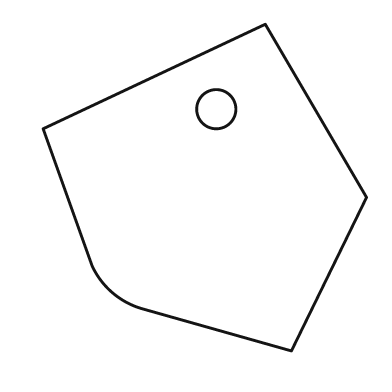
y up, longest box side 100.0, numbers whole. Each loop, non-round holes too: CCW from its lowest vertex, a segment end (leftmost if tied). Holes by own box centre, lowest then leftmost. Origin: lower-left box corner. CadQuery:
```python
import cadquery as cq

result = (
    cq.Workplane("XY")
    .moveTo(76.0, 0.0)
    .lineTo(99.0, 47.0)
    .lineTo(68.0, 100.0)
    .lineTo(0.0, 68.0)
    .lineTo(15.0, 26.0)
    .threePointArc((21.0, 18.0), (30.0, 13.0))
    .close()
    .moveTo(53.0, 74.0)
    .circle(6.0)
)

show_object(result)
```